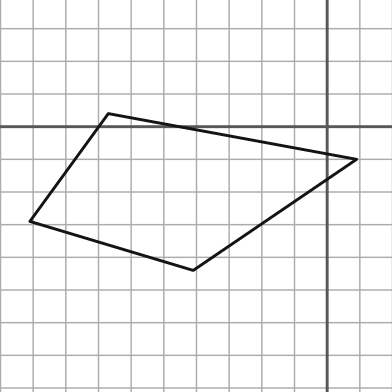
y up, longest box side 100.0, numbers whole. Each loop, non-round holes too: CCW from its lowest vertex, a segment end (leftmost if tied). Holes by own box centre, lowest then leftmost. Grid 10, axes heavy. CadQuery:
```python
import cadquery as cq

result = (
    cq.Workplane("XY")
    .moveTo(-41.0, -44.0)
    .lineTo(9.0, -10.0)
    .lineTo(-67.0, 4.0)
    .lineTo(-91.0, -29.0)
    .close()
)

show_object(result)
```